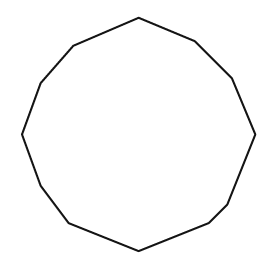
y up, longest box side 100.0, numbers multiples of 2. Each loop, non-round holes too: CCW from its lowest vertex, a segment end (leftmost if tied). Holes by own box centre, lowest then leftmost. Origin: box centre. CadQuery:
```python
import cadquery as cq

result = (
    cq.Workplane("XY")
    .moveTo(0.0, -50.0)
    .lineTo(30.0, -38.0)
    .lineTo(38.0, -30.0)
    .lineTo(50.0, 0.0)
    .lineTo(40.0, 24.0)
    .lineTo(24.0, 40.0)
    .lineTo(0.0, 50.0)
    .lineTo(-28.0, 38.0)
    .lineTo(-42.0, 22.0)
    .lineTo(-50.0, 0.0)
    .lineTo(-42.0, -22.0)
    .lineTo(-30.0, -38.0)
    .close()
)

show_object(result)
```